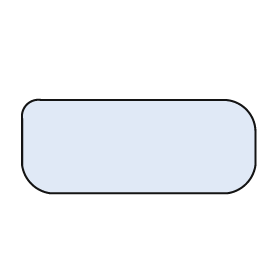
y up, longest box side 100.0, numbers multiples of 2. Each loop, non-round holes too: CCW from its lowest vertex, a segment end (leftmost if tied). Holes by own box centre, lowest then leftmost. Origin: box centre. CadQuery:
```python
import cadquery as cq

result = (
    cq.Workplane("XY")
    .moveTo(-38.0, -20.0)
    .lineTo(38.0, -20.0)
    .threePointArc((46.0, -16.0), (50.0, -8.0))
    .lineTo(50.0, 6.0)
    .threePointArc((46.0, 16.0), (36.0, 20.0))
    .lineTo(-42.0, 20.0)
    .threePointArc((-48.0, 18.0), (-50.0, 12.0))
    .lineTo(-50.0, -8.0)
    .threePointArc((-46.0, -16.0), (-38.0, -20.0))
    .close()
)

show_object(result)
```